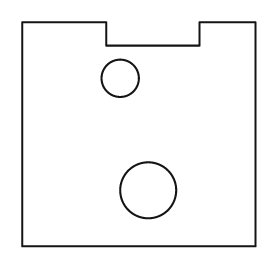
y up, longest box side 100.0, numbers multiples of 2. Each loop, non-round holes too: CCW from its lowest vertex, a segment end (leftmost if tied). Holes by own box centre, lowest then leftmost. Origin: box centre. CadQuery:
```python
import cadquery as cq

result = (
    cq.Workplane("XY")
    .moveTo(-50.0, -48.0)
    .lineTo(50.0, -48.0)
    .lineTo(50.0, 48.0)
    .lineTo(26.0, 48.0)
    .lineTo(26.0, 38.0)
    .lineTo(-14.0, 38.0)
    .lineTo(-14.0, 48.0)
    .lineTo(-50.0, 48.0)
    .close()
    .moveTo(4.0, -24.0)
    .circle(12.0)
    .moveTo(-8.0, 24.0)
    .circle(8.0)
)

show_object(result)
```